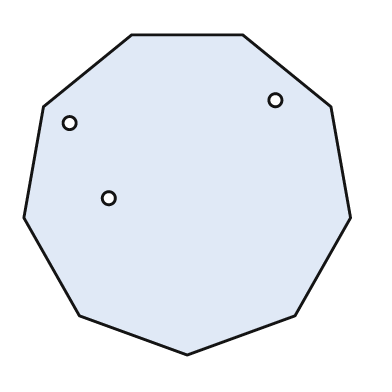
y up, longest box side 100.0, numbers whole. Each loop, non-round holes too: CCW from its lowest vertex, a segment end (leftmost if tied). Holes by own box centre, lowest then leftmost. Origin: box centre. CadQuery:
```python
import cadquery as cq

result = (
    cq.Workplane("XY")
    .moveTo(0.0, -49.0)
    .lineTo(33.0, -37.0)
    .lineTo(50.0, -7.0)
    .lineTo(44.0, 27.0)
    .lineTo(17.0, 49.0)
    .lineTo(-17.0, 49.0)
    .lineTo(-44.0, 27.0)
    .lineTo(-50.0, -7.0)
    .lineTo(-33.0, -37.0)
    .close()
    .moveTo(-24.0, -1.0)
    .circle(2.0)
    .moveTo(-36.0, 22.0)
    .circle(2.0)
    .moveTo(27.0, 29.0)
    .circle(2.0)
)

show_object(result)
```